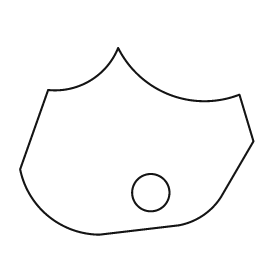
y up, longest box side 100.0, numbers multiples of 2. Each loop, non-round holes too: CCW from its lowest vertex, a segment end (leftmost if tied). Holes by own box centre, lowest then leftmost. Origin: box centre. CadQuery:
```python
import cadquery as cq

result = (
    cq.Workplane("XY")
    .moveTo(-16.0, -40.0)
    .lineTo(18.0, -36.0)
    .threePointArc((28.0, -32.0), (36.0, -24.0))
    .lineTo(50.0, 0.0)
    .lineTo(44.0, 20.0)
    .threePointArc((14.0, 20.0), (-8.0, 40.0))
    .threePointArc((-20.0, 26.0), (-38.0, 22.0))
    .lineTo(-50.0, -12.0)
    .threePointArc((-38.0, -32.0), (-16.0, -40.0))
    .close()
    .moveTo(6.0, -22.0)
    .circle(8.0)
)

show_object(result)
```